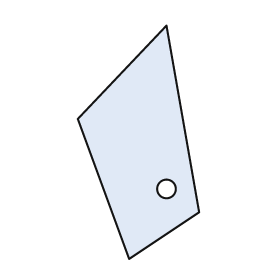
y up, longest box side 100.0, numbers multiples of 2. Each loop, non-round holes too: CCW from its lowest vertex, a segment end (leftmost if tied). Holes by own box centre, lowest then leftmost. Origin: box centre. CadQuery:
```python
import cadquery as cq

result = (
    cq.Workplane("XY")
    .moveTo(-4.0, -50.0)
    .lineTo(26.0, -30.0)
    .lineTo(12.0, 50.0)
    .lineTo(-26.0, 10.0)
    .close()
    .moveTo(12.0, -20.0)
    .circle(4.0)
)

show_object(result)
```